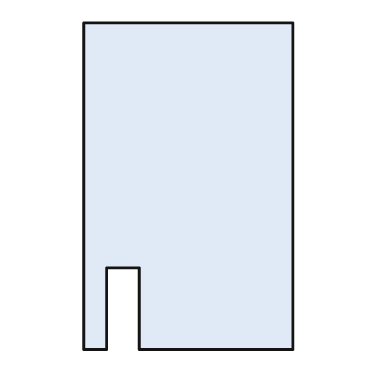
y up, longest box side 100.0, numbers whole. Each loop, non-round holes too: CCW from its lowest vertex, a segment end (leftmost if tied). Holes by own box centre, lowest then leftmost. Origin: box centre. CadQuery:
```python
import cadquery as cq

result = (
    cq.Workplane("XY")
    .moveTo(-32.0, -50.0)
    .lineTo(-25.0, -50.0)
    .lineTo(-25.0, -25.0)
    .lineTo(-15.0, -25.0)
    .lineTo(-15.0, -50.0)
    .lineTo(32.0, -50.0)
    .lineTo(32.0, 50.0)
    .lineTo(-32.0, 50.0)
    .close()
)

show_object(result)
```